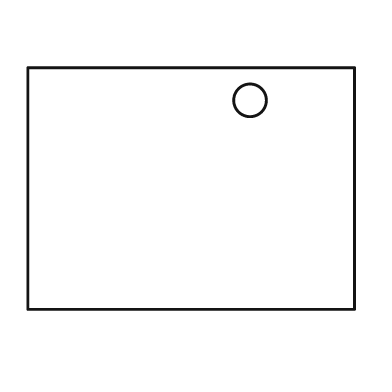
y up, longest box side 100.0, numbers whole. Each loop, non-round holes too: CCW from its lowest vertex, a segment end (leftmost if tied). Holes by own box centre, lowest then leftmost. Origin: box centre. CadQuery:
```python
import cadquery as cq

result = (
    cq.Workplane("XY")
    .moveTo(-50.0, -37.0)
    .lineTo(50.0, -37.0)
    .lineTo(50.0, 37.0)
    .lineTo(-50.0, 37.0)
    .close()
    .moveTo(18.0, 27.0)
    .circle(5.0)
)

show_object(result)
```